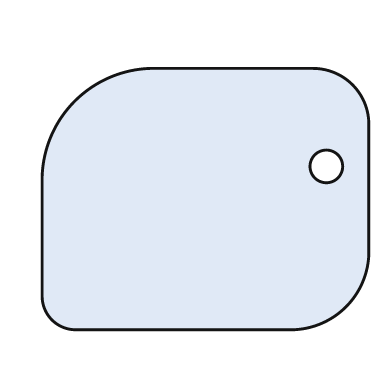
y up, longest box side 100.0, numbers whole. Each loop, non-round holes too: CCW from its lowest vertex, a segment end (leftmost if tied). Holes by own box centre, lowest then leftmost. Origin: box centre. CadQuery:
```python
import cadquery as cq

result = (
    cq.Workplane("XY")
    .moveTo(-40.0, -40.0)
    .lineTo(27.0, -40.0)
    .threePointArc((43.0, -33.0), (50.0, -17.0))
    .lineTo(50.0, 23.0)
    .threePointArc((45.0, 35.0), (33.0, 40.0))
    .lineTo(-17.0, 40.0)
    .threePointArc((-40.0, 30.0), (-50.0, 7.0))
    .lineTo(-50.0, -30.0)
    .threePointArc((-47.0, -37.0), (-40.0, -40.0))
    .close()
    .moveTo(37.0, 10.0)
    .circle(5.0)
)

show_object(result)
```